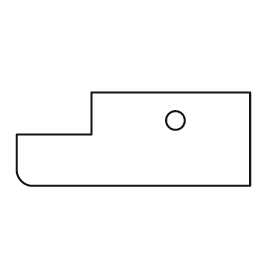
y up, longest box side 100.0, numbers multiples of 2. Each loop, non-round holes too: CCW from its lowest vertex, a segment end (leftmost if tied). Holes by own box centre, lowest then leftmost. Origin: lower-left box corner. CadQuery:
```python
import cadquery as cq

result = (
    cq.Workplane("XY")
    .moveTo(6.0, 0.0)
    .lineTo(100.0, 0.0)
    .lineTo(100.0, 40.0)
    .lineTo(32.0, 40.0)
    .lineTo(32.0, 22.0)
    .lineTo(0.0, 22.0)
    .lineTo(0.0, 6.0)
    .threePointArc((2.0, 2.0), (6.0, 0.0))
    .close()
    .moveTo(68.0, 28.0)
    .circle(4.0)
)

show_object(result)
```